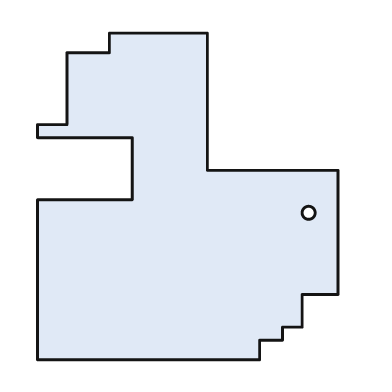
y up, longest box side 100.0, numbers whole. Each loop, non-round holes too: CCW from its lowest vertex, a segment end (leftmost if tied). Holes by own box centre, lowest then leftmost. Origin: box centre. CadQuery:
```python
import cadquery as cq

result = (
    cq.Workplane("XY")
    .moveTo(-46.0, -50.0)
    .lineTo(22.0, -50.0)
    .lineTo(22.0, -44.0)
    .lineTo(29.0, -44.0)
    .lineTo(29.0, -40.0)
    .lineTo(35.0, -40.0)
    .lineTo(35.0, -30.0)
    .lineTo(46.0, -30.0)
    .lineTo(46.0, 8.0)
    .lineTo(6.0, 8.0)
    .lineTo(6.0, 50.0)
    .lineTo(-24.0, 50.0)
    .lineTo(-24.0, 44.0)
    .lineTo(-37.0, 44.0)
    .lineTo(-37.0, 22.0)
    .lineTo(-46.0, 22.0)
    .lineTo(-46.0, 18.0)
    .lineTo(-17.0, 18.0)
    .lineTo(-17.0, -1.0)
    .lineTo(-46.0, -1.0)
    .close()
    .moveTo(37.0, -5.0)
    .circle(2.0)
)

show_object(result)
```